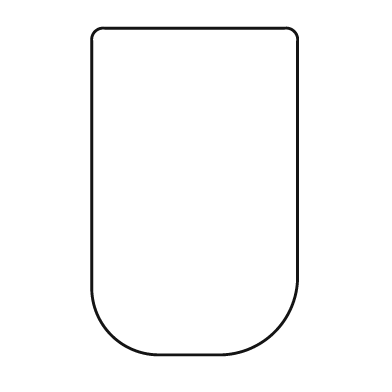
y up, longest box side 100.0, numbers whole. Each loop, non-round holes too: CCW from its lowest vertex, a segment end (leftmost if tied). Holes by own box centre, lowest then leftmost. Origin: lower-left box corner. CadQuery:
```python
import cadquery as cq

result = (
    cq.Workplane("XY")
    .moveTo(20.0, 0.0)
    .lineTo(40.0, 0.0)
    .threePointArc((56.0, 7.0), (63.0, 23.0))
    .lineTo(63.0, 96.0)
    .threePointArc((62.0, 99.0), (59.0, 100.0))
    .lineTo(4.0, 100.0)
    .threePointArc((1.0, 99.0), (0.0, 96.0))
    .lineTo(0.0, 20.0)
    .threePointArc((6.0, 6.0), (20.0, 0.0))
    .close()
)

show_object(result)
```